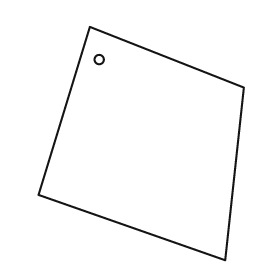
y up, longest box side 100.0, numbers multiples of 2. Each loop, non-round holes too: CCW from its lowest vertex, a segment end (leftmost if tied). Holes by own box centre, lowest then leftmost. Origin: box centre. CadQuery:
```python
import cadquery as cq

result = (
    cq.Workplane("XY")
    .moveTo(36.0, -50.0)
    .lineTo(44.0, 24.0)
    .lineTo(-22.0, 50.0)
    .lineTo(-44.0, -22.0)
    .close()
    .moveTo(-18.0, 36.0)
    .circle(2.0)
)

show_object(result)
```